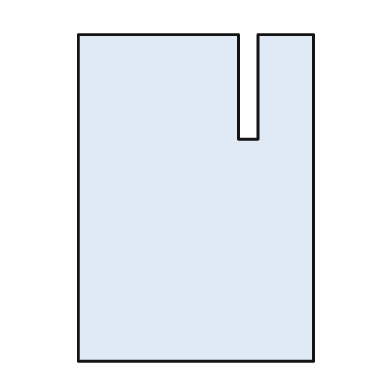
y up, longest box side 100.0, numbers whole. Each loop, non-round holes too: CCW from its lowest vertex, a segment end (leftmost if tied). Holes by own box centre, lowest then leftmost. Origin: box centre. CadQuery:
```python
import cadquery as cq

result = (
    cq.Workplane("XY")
    .moveTo(-36.0, -50.0)
    .lineTo(36.0, -50.0)
    .lineTo(36.0, 50.0)
    .lineTo(19.0, 50.0)
    .lineTo(19.0, 18.0)
    .lineTo(13.0, 18.0)
    .lineTo(13.0, 50.0)
    .lineTo(-36.0, 50.0)
    .close()
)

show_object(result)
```